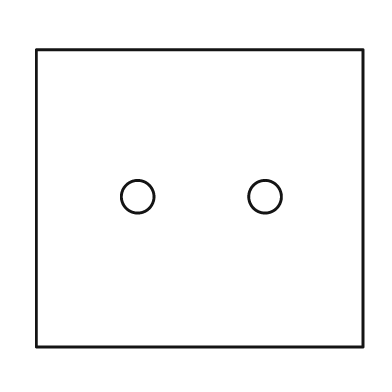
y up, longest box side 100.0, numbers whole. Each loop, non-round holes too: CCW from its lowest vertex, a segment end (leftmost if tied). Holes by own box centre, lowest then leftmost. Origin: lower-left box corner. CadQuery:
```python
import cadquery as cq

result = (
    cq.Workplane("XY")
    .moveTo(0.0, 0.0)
    .lineTo(100.0, 0.0)
    .lineTo(100.0, 91.0)
    .lineTo(0.0, 91.0)
    .close()
    .moveTo(31.0, 46.0)
    .circle(5.0)
    .moveTo(70.0, 46.0)
    .circle(5.0)
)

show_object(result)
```